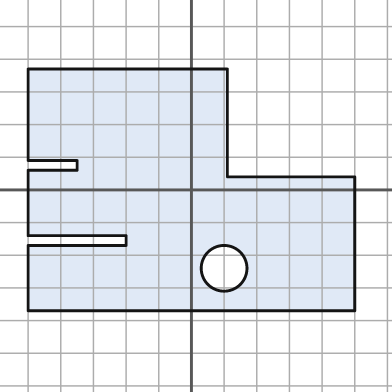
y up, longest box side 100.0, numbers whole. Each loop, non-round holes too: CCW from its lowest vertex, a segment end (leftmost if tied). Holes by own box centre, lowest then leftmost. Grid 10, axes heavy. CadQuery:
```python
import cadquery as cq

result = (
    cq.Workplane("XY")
    .moveTo(-50.0, -37.0)
    .lineTo(50.0, -37.0)
    .lineTo(50.0, 4.0)
    .lineTo(11.0, 4.0)
    .lineTo(11.0, 37.0)
    .lineTo(-50.0, 37.0)
    .lineTo(-50.0, 9.0)
    .lineTo(-35.0, 9.0)
    .lineTo(-35.0, 6.0)
    .lineTo(-50.0, 6.0)
    .lineTo(-50.0, -14.0)
    .lineTo(-20.0, -14.0)
    .lineTo(-20.0, -17.0)
    .lineTo(-50.0, -17.0)
    .close()
    .moveTo(10.0, -24.0)
    .circle(7.0)
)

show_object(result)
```